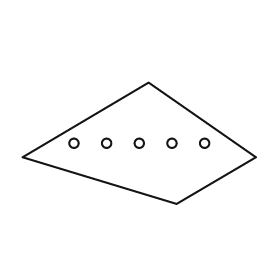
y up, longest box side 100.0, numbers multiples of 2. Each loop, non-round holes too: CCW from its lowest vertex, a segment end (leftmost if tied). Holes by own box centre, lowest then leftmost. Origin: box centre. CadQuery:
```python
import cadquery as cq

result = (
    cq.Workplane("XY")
    .moveTo(16.0, -26.0)
    .lineTo(50.0, -6.0)
    .lineTo(4.0, 26.0)
    .lineTo(-50.0, -6.0)
    .close()
    .moveTo(-28.0, 0.0)
    .circle(2.0)
    .moveTo(-14.0, 0.0)
    .circle(2.0)
    .moveTo(0.0, 0.0)
    .circle(2.0)
    .moveTo(14.0, 0.0)
    .circle(2.0)
    .moveTo(28.0, 0.0)
    .circle(2.0)
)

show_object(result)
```